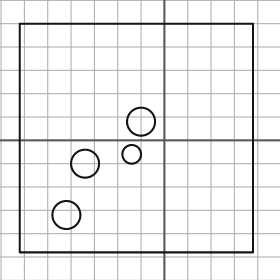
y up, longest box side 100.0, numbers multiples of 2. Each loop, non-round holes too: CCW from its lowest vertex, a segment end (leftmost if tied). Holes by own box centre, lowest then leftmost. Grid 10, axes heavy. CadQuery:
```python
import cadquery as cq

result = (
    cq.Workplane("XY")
    .moveTo(-62.0, -48.0)
    .lineTo(38.0, -48.0)
    .lineTo(38.0, 50.0)
    .lineTo(-62.0, 50.0)
    .close()
    .moveTo(-42.0, -32.0)
    .circle(6.0)
    .moveTo(-34.0, -10.0)
    .circle(6.0)
    .moveTo(-14.0, -6.0)
    .circle(4.0)
    .moveTo(-10.0, 8.0)
    .circle(6.0)
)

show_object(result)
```